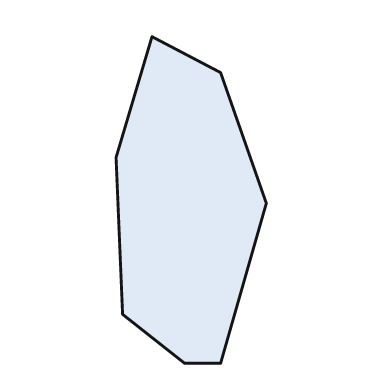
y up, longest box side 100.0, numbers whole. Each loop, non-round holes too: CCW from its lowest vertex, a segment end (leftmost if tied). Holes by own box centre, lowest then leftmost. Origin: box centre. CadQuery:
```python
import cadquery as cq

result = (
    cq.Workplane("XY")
    .moveTo(-2.0, -50.0)
    .lineTo(9.0, -50.0)
    .lineTo(23.0, -1.0)
    .lineTo(9.0, 39.0)
    .lineTo(-12.0, 50.0)
    .lineTo(-23.0, 13.0)
    .lineTo(-21.0, -35.0)
    .close()
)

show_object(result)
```